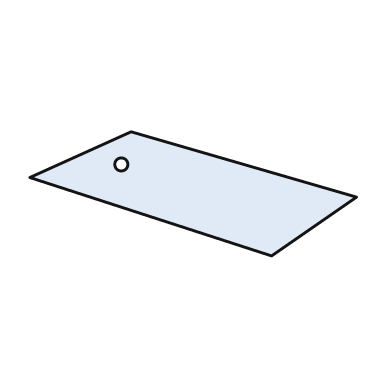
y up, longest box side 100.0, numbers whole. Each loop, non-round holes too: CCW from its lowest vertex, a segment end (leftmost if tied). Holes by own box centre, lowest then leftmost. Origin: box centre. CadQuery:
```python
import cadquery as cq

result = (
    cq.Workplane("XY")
    .moveTo(24.0, -19.0)
    .lineTo(50.0, -1.0)
    .lineTo(-19.0, 19.0)
    .lineTo(-50.0, 5.0)
    .close()
    .moveTo(-22.0, 9.0)
    .circle(2.0)
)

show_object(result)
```